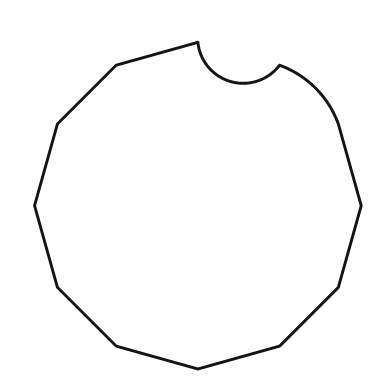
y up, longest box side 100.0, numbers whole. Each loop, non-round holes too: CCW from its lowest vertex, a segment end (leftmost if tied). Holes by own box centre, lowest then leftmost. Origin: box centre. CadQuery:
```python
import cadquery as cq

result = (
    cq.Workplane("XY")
    .moveTo(0.0, -50.0)
    .lineTo(25.0, -43.0)
    .lineTo(43.0, -25.0)
    .lineTo(50.0, 0.0)
    .lineTo(43.0, 25.0)
    .threePointArc((36.0, 36.0), (25.0, 43.0))
    .threePointArc((10.0, 38.0), (0.0, 50.0))
    .lineTo(-25.0, 43.0)
    .lineTo(-43.0, 25.0)
    .lineTo(-50.0, 0.0)
    .lineTo(-43.0, -25.0)
    .lineTo(-25.0, -43.0)
    .close()
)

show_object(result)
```